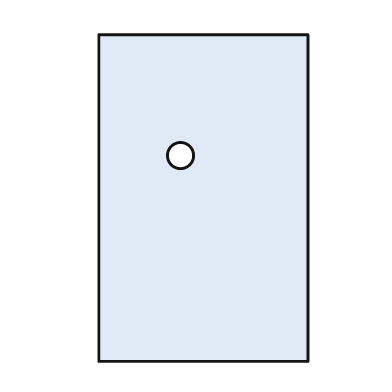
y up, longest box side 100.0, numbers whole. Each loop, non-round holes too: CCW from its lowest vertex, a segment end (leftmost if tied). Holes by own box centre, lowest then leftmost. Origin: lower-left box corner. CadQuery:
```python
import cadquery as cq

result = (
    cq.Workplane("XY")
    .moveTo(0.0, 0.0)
    .lineTo(64.0, 0.0)
    .lineTo(64.0, 100.0)
    .lineTo(0.0, 100.0)
    .close()
    .moveTo(25.0, 63.0)
    .circle(4.0)
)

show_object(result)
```